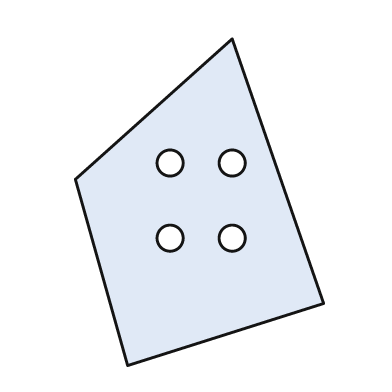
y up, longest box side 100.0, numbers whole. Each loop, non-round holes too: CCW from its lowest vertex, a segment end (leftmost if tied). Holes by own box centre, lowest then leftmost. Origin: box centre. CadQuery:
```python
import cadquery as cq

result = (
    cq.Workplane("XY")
    .moveTo(-22.0, -50.0)
    .lineTo(38.0, -31.0)
    .lineTo(10.0, 50.0)
    .lineTo(-38.0, 7.0)
    .close()
    .moveTo(-9.0, -11.0)
    .circle(4.0)
    .moveTo(10.0, -11.0)
    .circle(4.0)
    .moveTo(-9.0, 12.0)
    .circle(4.0)
    .moveTo(10.0, 12.0)
    .circle(4.0)
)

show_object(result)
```